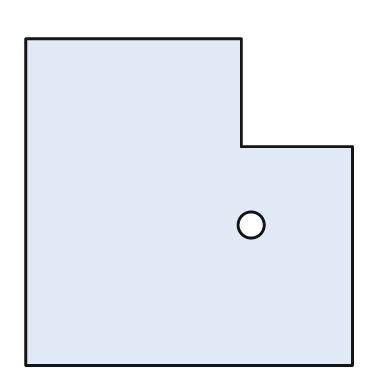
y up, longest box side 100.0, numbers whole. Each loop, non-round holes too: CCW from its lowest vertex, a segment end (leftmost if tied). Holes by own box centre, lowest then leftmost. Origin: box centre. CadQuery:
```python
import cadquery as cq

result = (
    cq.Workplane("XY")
    .moveTo(-50.0, -50.0)
    .lineTo(50.0, -50.0)
    .lineTo(50.0, 17.0)
    .lineTo(16.0, 17.0)
    .lineTo(16.0, 50.0)
    .lineTo(-50.0, 50.0)
    .close()
    .moveTo(19.0, -7.0)
    .circle(4.0)
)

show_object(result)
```